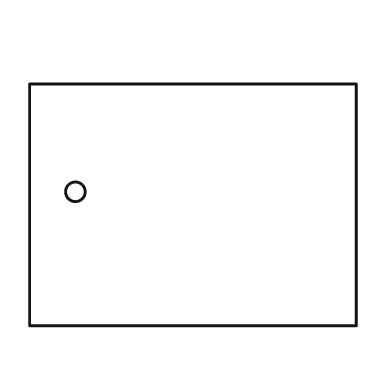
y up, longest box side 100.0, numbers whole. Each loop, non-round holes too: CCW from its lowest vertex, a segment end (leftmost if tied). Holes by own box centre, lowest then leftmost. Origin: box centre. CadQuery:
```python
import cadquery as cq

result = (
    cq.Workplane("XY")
    .moveTo(-50.0, -37.0)
    .lineTo(50.0, -37.0)
    .lineTo(50.0, 37.0)
    .lineTo(-50.0, 37.0)
    .close()
    .moveTo(-36.0, 4.0)
    .circle(3.0)
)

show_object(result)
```